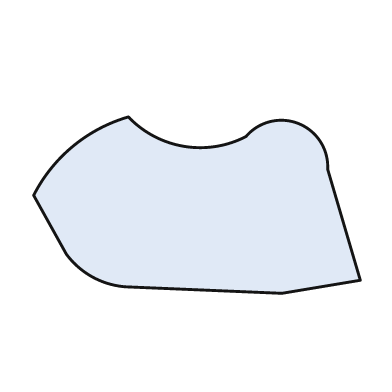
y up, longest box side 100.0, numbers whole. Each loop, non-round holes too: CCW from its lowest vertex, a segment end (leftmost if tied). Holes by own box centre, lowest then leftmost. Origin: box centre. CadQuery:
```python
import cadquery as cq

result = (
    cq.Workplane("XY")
    .moveTo(26.0, -27.0)
    .lineTo(50.0, -23.0)
    .lineTo(40.0, 11.0)
    .threePointArc((31.0, 25.0), (15.0, 21.0))
    .threePointArc((-4.0, 18.0), (-21.0, 27.0))
    .threePointArc((-38.0, 18.0), (-50.0, 3.0))
    .lineTo(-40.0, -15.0)
    .threePointArc((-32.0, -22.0), (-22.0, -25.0))
    .close()
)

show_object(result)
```